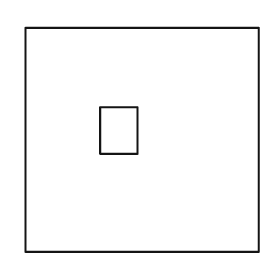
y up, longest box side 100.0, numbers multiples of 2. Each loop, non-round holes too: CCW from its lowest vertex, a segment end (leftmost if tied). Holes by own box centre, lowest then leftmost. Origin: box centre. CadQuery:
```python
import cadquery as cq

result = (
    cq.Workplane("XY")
    .moveTo(-50.0, -48.0)
    .lineTo(50.0, -48.0)
    .lineTo(50.0, 48.0)
    .lineTo(-50.0, 48.0)
    .close()
    .moveTo(-18.0, -6.0)
    .lineTo(-2.0, -6.0)
    .lineTo(-2.0, 14.0)
    .lineTo(-18.0, 14.0)
    .close()
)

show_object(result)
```